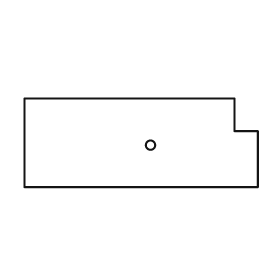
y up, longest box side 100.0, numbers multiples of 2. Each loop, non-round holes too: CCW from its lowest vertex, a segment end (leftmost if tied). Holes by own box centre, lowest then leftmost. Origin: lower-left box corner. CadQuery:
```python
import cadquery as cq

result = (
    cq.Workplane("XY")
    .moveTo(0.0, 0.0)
    .lineTo(100.0, 0.0)
    .lineTo(100.0, 24.0)
    .lineTo(90.0, 24.0)
    .lineTo(90.0, 38.0)
    .lineTo(0.0, 38.0)
    .close()
    .moveTo(54.0, 18.0)
    .circle(2.0)
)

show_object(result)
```